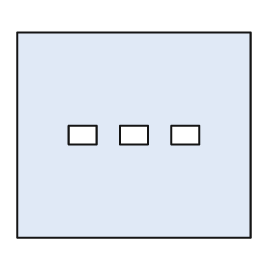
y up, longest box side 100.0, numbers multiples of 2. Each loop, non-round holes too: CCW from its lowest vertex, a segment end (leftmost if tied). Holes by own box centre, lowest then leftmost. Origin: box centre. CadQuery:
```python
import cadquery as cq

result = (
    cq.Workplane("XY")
    .moveTo(-50.0, -44.0)
    .lineTo(50.0, -44.0)
    .lineTo(50.0, 44.0)
    .lineTo(-50.0, 44.0)
    .close()
    .moveTo(-28.0, -4.0)
    .lineTo(-16.0, -4.0)
    .lineTo(-16.0, 4.0)
    .lineTo(-28.0, 4.0)
    .close()
    .moveTo(-6.0, -4.0)
    .lineTo(6.0, -4.0)
    .lineTo(6.0, 4.0)
    .lineTo(-6.0, 4.0)
    .close()
    .moveTo(16.0, -4.0)
    .lineTo(28.0, -4.0)
    .lineTo(28.0, 4.0)
    .lineTo(16.0, 4.0)
    .close()
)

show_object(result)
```